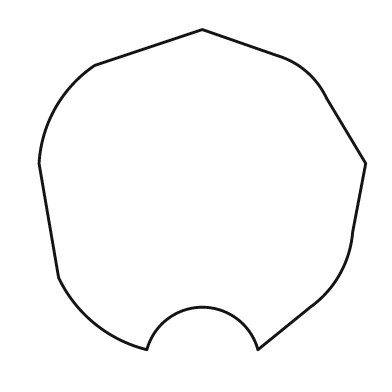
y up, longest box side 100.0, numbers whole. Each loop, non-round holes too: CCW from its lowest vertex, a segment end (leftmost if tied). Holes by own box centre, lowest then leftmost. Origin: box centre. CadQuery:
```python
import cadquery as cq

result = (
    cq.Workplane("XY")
    .moveTo(-17.0, -49.0)
    .threePointArc((0.0, -36.0), (17.0, -49.0))
    .lineTo(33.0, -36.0)
    .threePointArc((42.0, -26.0), (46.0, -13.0))
    .lineTo(50.0, 8.0)
    .lineTo(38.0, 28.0)
    .threePointArc((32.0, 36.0), (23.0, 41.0))
    .lineTo(0.0, 49.0)
    .lineTo(-33.0, 38.0)
    .threePointArc((-45.0, 25.0), (-50.0, 8.0))
    .lineTo(-44.0, -27.0)
    .threePointArc((-33.0, -41.0), (-17.0, -49.0))
    .close()
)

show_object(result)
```